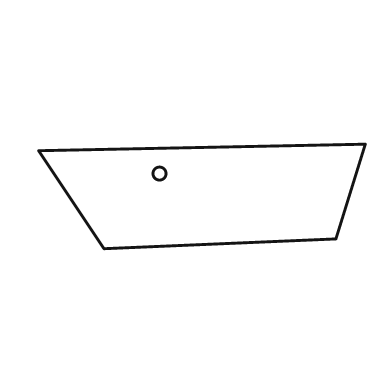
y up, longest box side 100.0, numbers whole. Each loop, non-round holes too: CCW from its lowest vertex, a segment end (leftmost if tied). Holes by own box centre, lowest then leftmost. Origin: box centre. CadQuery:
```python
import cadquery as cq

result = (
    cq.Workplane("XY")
    .moveTo(-30.0, -16.0)
    .lineTo(41.0, -13.0)
    .lineTo(50.0, 16.0)
    .lineTo(-50.0, 14.0)
    .close()
    .moveTo(-13.0, 7.0)
    .circle(2.0)
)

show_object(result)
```